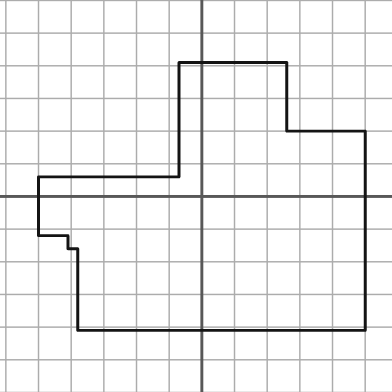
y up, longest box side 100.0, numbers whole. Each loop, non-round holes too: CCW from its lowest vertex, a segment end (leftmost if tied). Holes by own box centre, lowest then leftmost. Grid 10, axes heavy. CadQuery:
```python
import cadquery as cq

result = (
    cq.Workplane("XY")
    .moveTo(-38.0, -41.0)
    .lineTo(50.0, -41.0)
    .lineTo(50.0, 20.0)
    .lineTo(26.0, 20.0)
    .lineTo(26.0, 41.0)
    .lineTo(-7.0, 41.0)
    .lineTo(-7.0, 6.0)
    .lineTo(-50.0, 6.0)
    .lineTo(-50.0, -12.0)
    .lineTo(-41.0, -12.0)
    .lineTo(-41.0, -16.0)
    .lineTo(-38.0, -16.0)
    .close()
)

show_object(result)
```